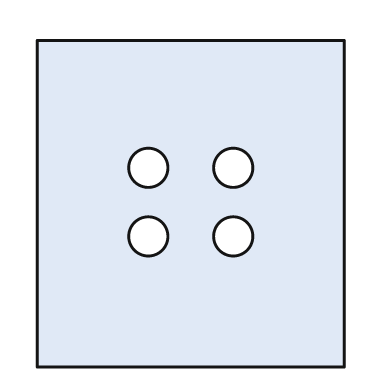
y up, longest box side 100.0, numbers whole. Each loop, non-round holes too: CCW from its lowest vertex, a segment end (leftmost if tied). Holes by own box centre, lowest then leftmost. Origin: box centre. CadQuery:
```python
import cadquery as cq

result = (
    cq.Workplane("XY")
    .moveTo(-47.0, -50.0)
    .lineTo(47.0, -50.0)
    .lineTo(47.0, 50.0)
    .lineTo(-47.0, 50.0)
    .close()
    .moveTo(-13.0, -10.0)
    .circle(6.0)
    .moveTo(13.0, -10.0)
    .circle(6.0)
    .moveTo(-13.0, 11.0)
    .circle(6.0)
    .moveTo(13.0, 11.0)
    .circle(6.0)
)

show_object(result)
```